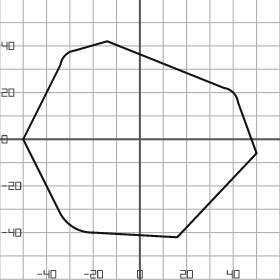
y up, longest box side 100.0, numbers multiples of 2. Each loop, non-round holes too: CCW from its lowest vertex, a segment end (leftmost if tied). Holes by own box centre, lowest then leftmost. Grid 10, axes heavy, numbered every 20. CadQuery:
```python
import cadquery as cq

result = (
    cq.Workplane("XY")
    .moveTo(16.0, -42.0)
    .lineTo(50.0, -6.0)
    .lineTo(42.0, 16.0)
    .threePointArc((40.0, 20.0), (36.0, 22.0))
    .lineTo(-14.0, 42.0)
    .lineTo(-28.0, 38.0)
    .threePointArc((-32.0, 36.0), (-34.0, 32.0))
    .lineTo(-50.0, 0.0)
    .lineTo(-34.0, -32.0)
    .threePointArc((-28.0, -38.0), (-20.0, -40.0))
    .close()
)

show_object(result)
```